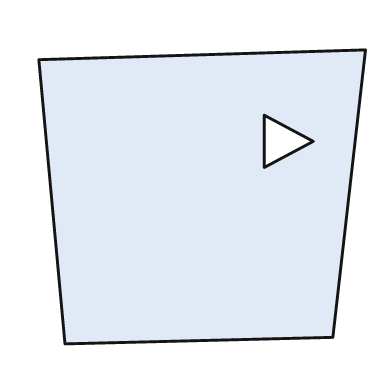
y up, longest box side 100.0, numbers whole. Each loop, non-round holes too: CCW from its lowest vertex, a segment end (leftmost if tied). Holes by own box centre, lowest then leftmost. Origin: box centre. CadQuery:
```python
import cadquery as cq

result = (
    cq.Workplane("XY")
    .moveTo(-42.0, -45.0)
    .lineTo(40.0, -43.0)
    .lineTo(50.0, 45.0)
    .lineTo(-50.0, 42.0)
    .close()
    .moveTo(19.0, 9.0)
    .lineTo(34.0, 17.0)
    .lineTo(19.0, 25.0)
    .close()
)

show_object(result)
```